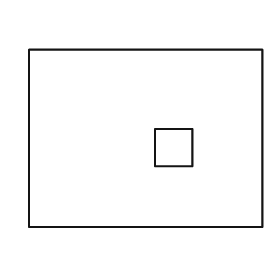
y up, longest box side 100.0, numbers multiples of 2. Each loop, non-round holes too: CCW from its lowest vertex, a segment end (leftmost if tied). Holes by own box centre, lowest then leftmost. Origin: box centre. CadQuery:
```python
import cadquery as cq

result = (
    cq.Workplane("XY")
    .moveTo(-50.0, -38.0)
    .lineTo(50.0, -38.0)
    .lineTo(50.0, 38.0)
    .lineTo(-50.0, 38.0)
    .close()
    .moveTo(4.0, -12.0)
    .lineTo(20.0, -12.0)
    .lineTo(20.0, 4.0)
    .lineTo(4.0, 4.0)
    .close()
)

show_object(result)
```